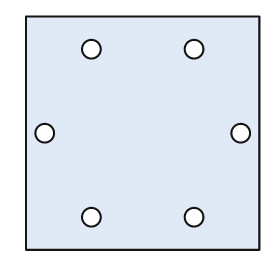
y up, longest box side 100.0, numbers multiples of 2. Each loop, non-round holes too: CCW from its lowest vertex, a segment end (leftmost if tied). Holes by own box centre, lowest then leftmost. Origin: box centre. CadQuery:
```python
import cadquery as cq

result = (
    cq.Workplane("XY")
    .moveTo(-50.0, -50.0)
    .lineTo(50.0, -50.0)
    .lineTo(50.0, 50.0)
    .lineTo(-50.0, 50.0)
    .close()
    .moveTo(-22.0, -36.0)
    .circle(4.0)
    .moveTo(22.0, -36.0)
    .circle(4.0)
    .moveTo(-42.0, 0.0)
    .circle(4.0)
    .moveTo(42.0, 0.0)
    .circle(4.0)
    .moveTo(-22.0, 36.0)
    .circle(4.0)
    .moveTo(22.0, 36.0)
    .circle(4.0)
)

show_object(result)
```